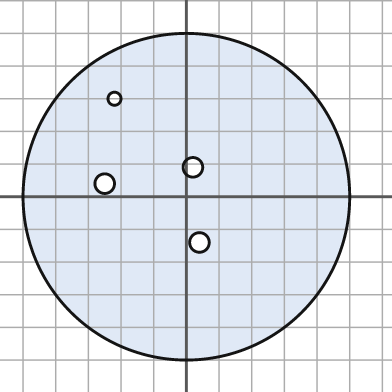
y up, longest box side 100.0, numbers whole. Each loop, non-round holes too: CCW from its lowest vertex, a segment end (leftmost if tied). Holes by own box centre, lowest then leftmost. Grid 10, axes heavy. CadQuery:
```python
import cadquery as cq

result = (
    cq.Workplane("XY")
    .moveTo(0.0, 0.0)
    .circle(50.0)
    .moveTo(4.0, -14.0)
    .circle(3.0)
    .moveTo(-25.0, 4.0)
    .circle(3.0)
    .moveTo(2.0, 9.0)
    .circle(3.0)
    .moveTo(-22.0, 30.0)
    .circle(2.0)
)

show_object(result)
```